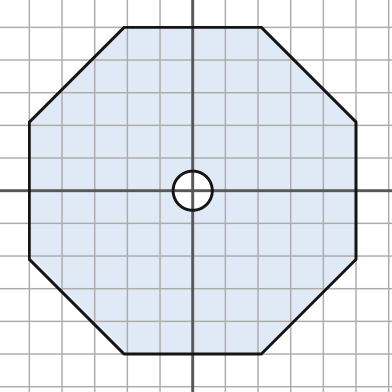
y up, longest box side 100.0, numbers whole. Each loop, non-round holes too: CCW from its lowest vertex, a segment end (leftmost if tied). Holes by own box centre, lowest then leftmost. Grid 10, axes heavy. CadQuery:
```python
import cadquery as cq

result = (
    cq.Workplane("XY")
    .moveTo(-21.0, -50.0)
    .lineTo(21.0, -50.0)
    .lineTo(50.0, -21.0)
    .lineTo(50.0, 21.0)
    .lineTo(21.0, 50.0)
    .lineTo(-21.0, 50.0)
    .lineTo(-50.0, 21.0)
    .lineTo(-50.0, -21.0)
    .close()
    .moveTo(0.0, 0.0)
    .circle(6.0)
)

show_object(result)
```